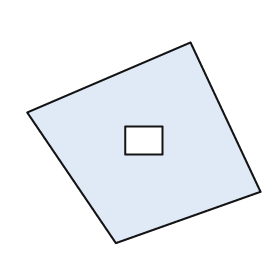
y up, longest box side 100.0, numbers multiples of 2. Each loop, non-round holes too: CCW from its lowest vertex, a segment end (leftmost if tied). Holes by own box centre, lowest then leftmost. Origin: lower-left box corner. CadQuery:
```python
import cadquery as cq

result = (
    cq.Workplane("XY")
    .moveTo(38.0, 0.0)
    .lineTo(100.0, 22.0)
    .lineTo(70.0, 86.0)
    .lineTo(0.0, 56.0)
    .close()
    .moveTo(42.0, 38.0)
    .lineTo(58.0, 38.0)
    .lineTo(58.0, 50.0)
    .lineTo(42.0, 50.0)
    .close()
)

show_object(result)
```